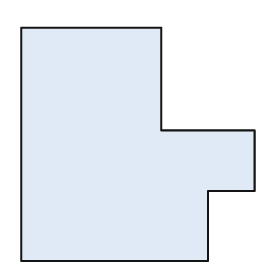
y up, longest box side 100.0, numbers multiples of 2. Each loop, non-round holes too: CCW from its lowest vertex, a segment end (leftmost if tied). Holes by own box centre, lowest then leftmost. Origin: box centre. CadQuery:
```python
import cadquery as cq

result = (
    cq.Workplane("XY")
    .moveTo(-50.0, -50.0)
    .lineTo(30.0, -50.0)
    .lineTo(30.0, -20.0)
    .lineTo(50.0, -20.0)
    .lineTo(50.0, 6.0)
    .lineTo(10.0, 6.0)
    .lineTo(10.0, 50.0)
    .lineTo(-50.0, 50.0)
    .close()
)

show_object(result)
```